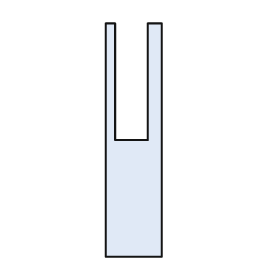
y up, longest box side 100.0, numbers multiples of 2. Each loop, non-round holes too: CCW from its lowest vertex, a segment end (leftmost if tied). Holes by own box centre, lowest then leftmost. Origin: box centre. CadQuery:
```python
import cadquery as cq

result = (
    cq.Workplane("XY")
    .moveTo(-12.0, -50.0)
    .lineTo(12.0, -50.0)
    .lineTo(12.0, 50.0)
    .lineTo(6.0, 50.0)
    .lineTo(6.0, 0.0)
    .lineTo(-8.0, 0.0)
    .lineTo(-8.0, 50.0)
    .lineTo(-12.0, 50.0)
    .close()
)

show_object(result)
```